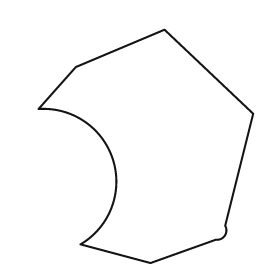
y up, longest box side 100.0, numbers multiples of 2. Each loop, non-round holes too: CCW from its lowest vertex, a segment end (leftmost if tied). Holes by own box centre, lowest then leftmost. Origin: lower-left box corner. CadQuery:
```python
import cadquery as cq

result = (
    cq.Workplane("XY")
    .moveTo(48.0, 0.0)
    .lineTo(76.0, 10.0)
    .threePointArc((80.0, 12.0), (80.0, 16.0))
    .lineTo(92.0, 64.0)
    .lineTo(54.0, 100.0)
    .lineTo(16.0, 84.0)
    .lineTo(0.0, 66.0)
    .threePointArc((32.0, 44.0), (18.0, 8.0))
    .close()
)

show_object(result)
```